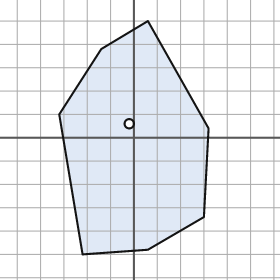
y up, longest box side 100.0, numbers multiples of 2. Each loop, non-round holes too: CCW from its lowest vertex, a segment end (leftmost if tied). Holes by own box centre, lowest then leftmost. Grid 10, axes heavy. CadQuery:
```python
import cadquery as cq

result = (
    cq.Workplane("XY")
    .moveTo(-22.0, -50.0)
    .lineTo(6.0, -48.0)
    .lineTo(30.0, -34.0)
    .lineTo(32.0, 4.0)
    .lineTo(6.0, 50.0)
    .lineTo(-14.0, 38.0)
    .lineTo(-32.0, 10.0)
    .close()
    .moveTo(-2.0, 6.0)
    .circle(2.0)
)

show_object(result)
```